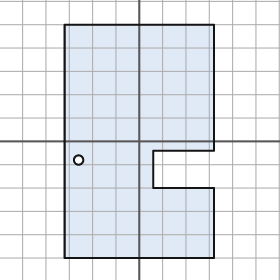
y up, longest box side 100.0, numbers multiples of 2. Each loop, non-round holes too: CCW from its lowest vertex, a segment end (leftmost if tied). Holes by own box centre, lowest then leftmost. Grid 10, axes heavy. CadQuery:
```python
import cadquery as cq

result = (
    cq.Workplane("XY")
    .moveTo(-32.0, -50.0)
    .lineTo(32.0, -50.0)
    .lineTo(32.0, -20.0)
    .lineTo(6.0, -20.0)
    .lineTo(6.0, -4.0)
    .lineTo(32.0, -4.0)
    .lineTo(32.0, 50.0)
    .lineTo(-32.0, 50.0)
    .close()
    .moveTo(-26.0, -8.0)
    .circle(2.0)
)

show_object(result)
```